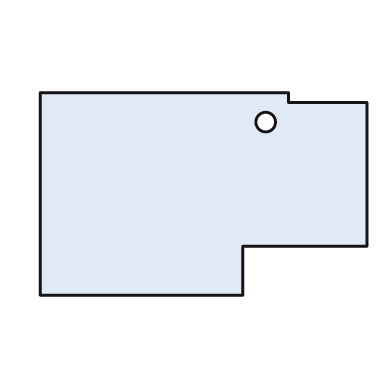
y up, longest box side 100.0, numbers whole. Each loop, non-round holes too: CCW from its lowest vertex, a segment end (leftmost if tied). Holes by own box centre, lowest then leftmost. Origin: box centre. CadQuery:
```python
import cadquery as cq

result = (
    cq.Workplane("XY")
    .moveTo(-50.0, -31.0)
    .lineTo(12.0, -31.0)
    .lineTo(12.0, -16.0)
    .lineTo(50.0, -16.0)
    .lineTo(50.0, 28.0)
    .lineTo(26.0, 28.0)
    .lineTo(26.0, 31.0)
    .lineTo(-50.0, 31.0)
    .close()
    .moveTo(19.0, 22.0)
    .circle(3.0)
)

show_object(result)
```